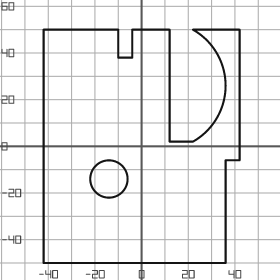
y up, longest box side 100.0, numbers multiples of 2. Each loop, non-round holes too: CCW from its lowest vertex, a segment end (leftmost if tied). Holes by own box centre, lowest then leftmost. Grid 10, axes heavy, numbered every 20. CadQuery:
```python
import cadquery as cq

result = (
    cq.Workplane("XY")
    .moveTo(-42.0, -50.0)
    .lineTo(36.0, -50.0)
    .lineTo(36.0, -6.0)
    .lineTo(42.0, -6.0)
    .lineTo(42.0, 50.0)
    .lineTo(22.0, 50.0)
    .threePointArc((36.0, 26.0), (22.0, 2.0))
    .lineTo(12.0, 2.0)
    .lineTo(12.0, 50.0)
    .lineTo(-4.0, 50.0)
    .lineTo(-4.0, 38.0)
    .lineTo(-10.0, 38.0)
    .lineTo(-10.0, 50.0)
    .lineTo(-42.0, 50.0)
    .close()
    .moveTo(-14.0, -14.0)
    .circle(8.0)
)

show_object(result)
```